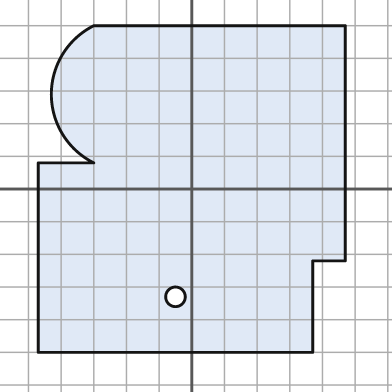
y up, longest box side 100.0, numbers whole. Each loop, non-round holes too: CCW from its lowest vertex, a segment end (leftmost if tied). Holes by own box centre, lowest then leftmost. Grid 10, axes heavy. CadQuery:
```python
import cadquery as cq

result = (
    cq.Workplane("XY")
    .moveTo(-47.0, -50.0)
    .lineTo(37.0, -50.0)
    .lineTo(37.0, -22.0)
    .lineTo(47.0, -22.0)
    .lineTo(47.0, 50.0)
    .lineTo(-30.0, 50.0)
    .threePointArc((-43.0, 29.0), (-30.0, 8.0))
    .lineTo(-47.0, 8.0)
    .close()
    .moveTo(-5.0, -33.0)
    .circle(3.0)
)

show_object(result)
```